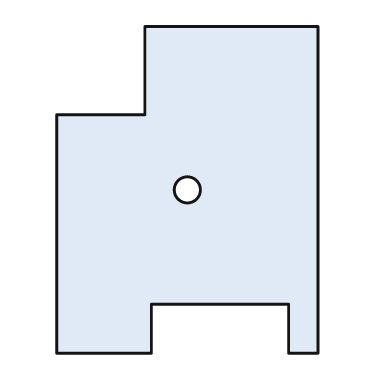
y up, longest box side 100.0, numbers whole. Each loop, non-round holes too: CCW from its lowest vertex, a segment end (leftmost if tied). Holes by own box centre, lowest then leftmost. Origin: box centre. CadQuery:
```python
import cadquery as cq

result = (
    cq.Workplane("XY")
    .moveTo(-40.0, -50.0)
    .lineTo(-11.0, -50.0)
    .lineTo(-11.0, -35.0)
    .lineTo(31.0, -35.0)
    .lineTo(31.0, -50.0)
    .lineTo(40.0, -50.0)
    .lineTo(40.0, 50.0)
    .lineTo(-13.0, 50.0)
    .lineTo(-13.0, 23.0)
    .lineTo(-40.0, 23.0)
    .close()
    .moveTo(0.0, 0.0)
    .circle(4.0)
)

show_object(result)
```